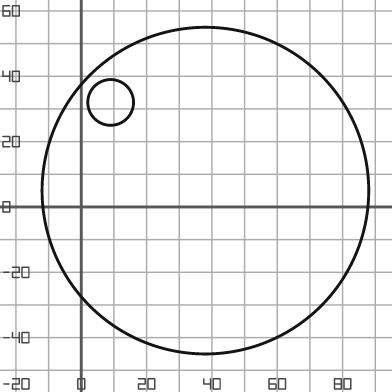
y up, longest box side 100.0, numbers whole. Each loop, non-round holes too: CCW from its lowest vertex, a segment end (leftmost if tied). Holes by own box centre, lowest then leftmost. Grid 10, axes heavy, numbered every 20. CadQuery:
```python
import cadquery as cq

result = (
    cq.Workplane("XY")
    .moveTo(38.0, 5.0)
    .circle(50.0)
    .moveTo(9.0, 32.0)
    .circle(7.0)
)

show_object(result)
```